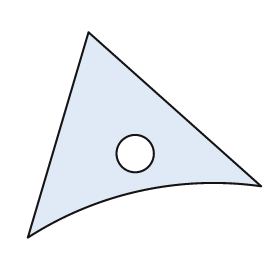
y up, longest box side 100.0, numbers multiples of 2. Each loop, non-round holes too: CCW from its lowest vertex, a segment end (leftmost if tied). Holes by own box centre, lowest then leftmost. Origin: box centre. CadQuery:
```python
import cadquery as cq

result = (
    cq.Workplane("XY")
    .moveTo(-50.0, -44.0)
    .threePointArc((-2.0, -24.0), (50.0, -22.0))
    .lineTo(-24.0, 44.0)
    .close()
    .moveTo(-4.0, -8.0)
    .circle(8.0)
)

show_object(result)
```